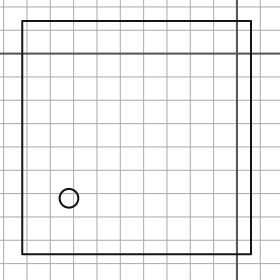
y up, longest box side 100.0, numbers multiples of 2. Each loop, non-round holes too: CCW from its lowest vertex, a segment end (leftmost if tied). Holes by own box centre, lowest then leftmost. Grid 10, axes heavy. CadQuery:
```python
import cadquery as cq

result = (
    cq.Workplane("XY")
    .moveTo(-92.0, -86.0)
    .lineTo(6.0, -86.0)
    .lineTo(6.0, 14.0)
    .lineTo(-92.0, 14.0)
    .close()
    .moveTo(-72.0, -62.0)
    .circle(4.0)
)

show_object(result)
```